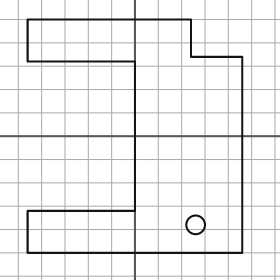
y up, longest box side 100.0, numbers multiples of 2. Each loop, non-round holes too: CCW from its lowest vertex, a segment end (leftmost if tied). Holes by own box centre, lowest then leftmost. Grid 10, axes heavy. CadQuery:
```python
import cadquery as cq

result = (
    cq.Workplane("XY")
    .moveTo(-46.0, -50.0)
    .lineTo(46.0, -50.0)
    .lineTo(46.0, 34.0)
    .lineTo(24.0, 34.0)
    .lineTo(24.0, 50.0)
    .lineTo(-46.0, 50.0)
    .lineTo(-46.0, 32.0)
    .lineTo(0.0, 32.0)
    .lineTo(0.0, -32.0)
    .lineTo(-46.0, -32.0)
    .close()
    .moveTo(26.0, -38.0)
    .circle(4.0)
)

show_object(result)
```